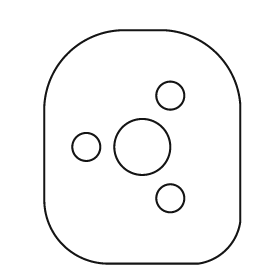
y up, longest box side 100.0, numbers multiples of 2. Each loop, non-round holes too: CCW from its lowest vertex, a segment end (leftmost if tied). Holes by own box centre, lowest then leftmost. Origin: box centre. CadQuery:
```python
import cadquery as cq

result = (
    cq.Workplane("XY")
    .moveTo(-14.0, -50.0)
    .lineTo(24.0, -50.0)
    .threePointArc((36.0, -44.0), (42.0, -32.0))
    .lineTo(42.0, 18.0)
    .threePointArc((32.0, 40.0), (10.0, 50.0))
    .lineTo(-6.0, 50.0)
    .threePointArc((-32.0, 40.0), (-42.0, 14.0))
    .lineTo(-42.0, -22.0)
    .threePointArc((-34.0, -42.0), (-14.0, -50.0))
    .close()
    .moveTo(12.0, -22.0)
    .circle(6.0)
    .moveTo(-24.0, 0.0)
    .circle(6.0)
    .moveTo(0.0, 0.0)
    .circle(12.0)
    .moveTo(12.0, 22.0)
    .circle(6.0)
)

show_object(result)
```